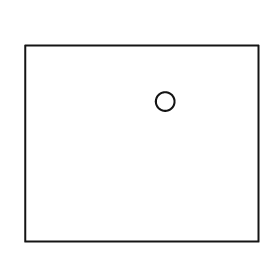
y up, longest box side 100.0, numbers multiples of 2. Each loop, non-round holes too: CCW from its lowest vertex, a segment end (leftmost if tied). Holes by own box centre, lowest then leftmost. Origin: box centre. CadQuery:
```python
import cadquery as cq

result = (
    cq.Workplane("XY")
    .moveTo(-50.0, -42.0)
    .lineTo(50.0, -42.0)
    .lineTo(50.0, 42.0)
    .lineTo(-50.0, 42.0)
    .close()
    .moveTo(10.0, 18.0)
    .circle(4.0)
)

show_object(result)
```